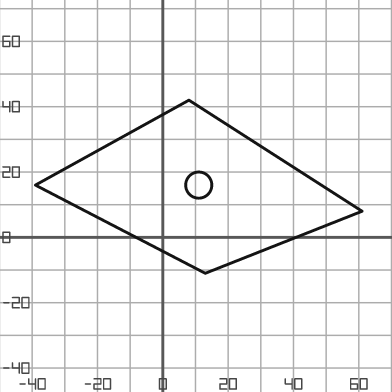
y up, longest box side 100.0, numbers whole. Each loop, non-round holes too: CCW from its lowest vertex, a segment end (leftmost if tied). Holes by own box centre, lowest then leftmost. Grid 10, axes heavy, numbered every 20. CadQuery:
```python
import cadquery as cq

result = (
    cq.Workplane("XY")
    .moveTo(13.0, -11.0)
    .lineTo(61.0, 8.0)
    .lineTo(8.0, 42.0)
    .lineTo(-39.0, 16.0)
    .close()
    .moveTo(11.0, 16.0)
    .circle(4.0)
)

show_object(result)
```